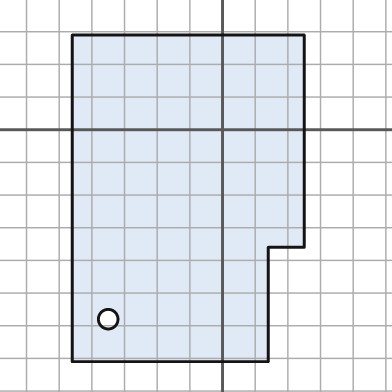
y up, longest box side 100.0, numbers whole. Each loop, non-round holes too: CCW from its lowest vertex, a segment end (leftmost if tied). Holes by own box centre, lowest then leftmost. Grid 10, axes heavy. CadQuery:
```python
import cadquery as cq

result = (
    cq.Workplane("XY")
    .moveTo(-46.0, -71.0)
    .lineTo(14.0, -71.0)
    .lineTo(14.0, -36.0)
    .lineTo(25.0, -36.0)
    .lineTo(25.0, 29.0)
    .lineTo(-46.0, 29.0)
    .close()
    .moveTo(-35.0, -58.0)
    .circle(3.0)
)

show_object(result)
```